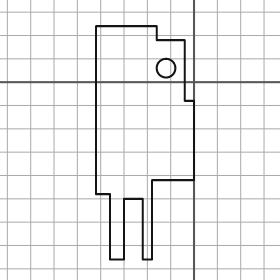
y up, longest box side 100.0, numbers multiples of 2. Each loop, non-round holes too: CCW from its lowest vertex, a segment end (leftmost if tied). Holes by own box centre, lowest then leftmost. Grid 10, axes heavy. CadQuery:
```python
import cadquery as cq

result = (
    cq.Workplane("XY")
    .moveTo(-36.0, -76.0)
    .lineTo(-30.0, -76.0)
    .lineTo(-30.0, -50.0)
    .lineTo(-22.0, -50.0)
    .lineTo(-22.0, -76.0)
    .lineTo(-18.0, -76.0)
    .lineTo(-18.0, -42.0)
    .lineTo(0.0, -42.0)
    .lineTo(0.0, -8.0)
    .lineTo(-4.0, -8.0)
    .lineTo(-4.0, 18.0)
    .lineTo(-16.0, 18.0)
    .lineTo(-16.0, 24.0)
    .lineTo(-42.0, 24.0)
    .lineTo(-42.0, -48.0)
    .lineTo(-36.0, -48.0)
    .close()
    .moveTo(-12.0, 6.0)
    .circle(4.0)
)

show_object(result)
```